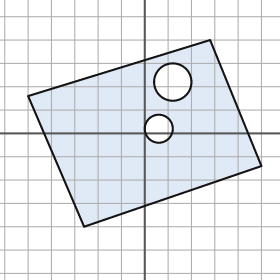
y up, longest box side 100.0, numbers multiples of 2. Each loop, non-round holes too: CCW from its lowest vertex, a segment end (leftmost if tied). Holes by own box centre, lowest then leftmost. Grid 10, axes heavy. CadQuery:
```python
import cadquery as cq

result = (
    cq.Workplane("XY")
    .moveTo(-26.0, -40.0)
    .lineTo(50.0, -14.0)
    .lineTo(28.0, 40.0)
    .lineTo(-50.0, 16.0)
    .close()
    .moveTo(6.0, 2.0)
    .circle(6.0)
    .moveTo(12.0, 22.0)
    .circle(8.0)
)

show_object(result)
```